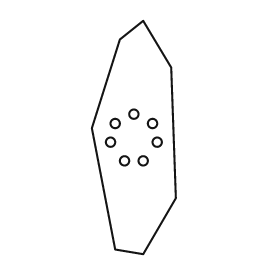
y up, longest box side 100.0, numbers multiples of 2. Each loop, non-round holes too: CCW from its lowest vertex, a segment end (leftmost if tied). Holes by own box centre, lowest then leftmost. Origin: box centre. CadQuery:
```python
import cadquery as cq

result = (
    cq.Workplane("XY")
    .moveTo(4.0, -50.0)
    .lineTo(18.0, -26.0)
    .lineTo(16.0, 30.0)
    .lineTo(4.0, 50.0)
    .lineTo(-6.0, 42.0)
    .lineTo(-18.0, 4.0)
    .lineTo(-8.0, -48.0)
    .close()
    .moveTo(-4.0, -10.0)
    .circle(2.0)
    .moveTo(4.0, -10.0)
    .circle(2.0)
    .moveTo(-10.0, -2.0)
    .circle(2.0)
    .moveTo(10.0, -2.0)
    .circle(2.0)
    .moveTo(-8.0, 6.0)
    .circle(2.0)
    .moveTo(8.0, 6.0)
    .circle(2.0)
    .moveTo(0.0, 10.0)
    .circle(2.0)
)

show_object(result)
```